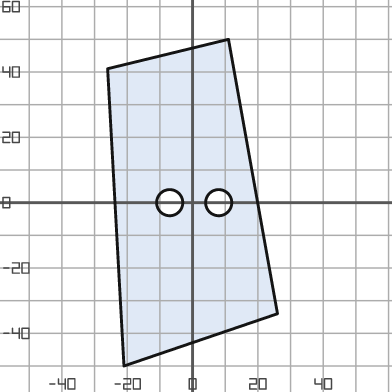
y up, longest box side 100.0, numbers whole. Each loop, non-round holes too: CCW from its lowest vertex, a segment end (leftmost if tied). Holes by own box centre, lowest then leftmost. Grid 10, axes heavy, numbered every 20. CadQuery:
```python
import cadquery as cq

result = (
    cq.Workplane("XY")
    .moveTo(-21.0, -50.0)
    .lineTo(26.0, -34.0)
    .lineTo(11.0, 50.0)
    .lineTo(-26.0, 41.0)
    .close()
    .moveTo(-7.0, 0.0)
    .circle(4.0)
    .moveTo(8.0, 0.0)
    .circle(4.0)
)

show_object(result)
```